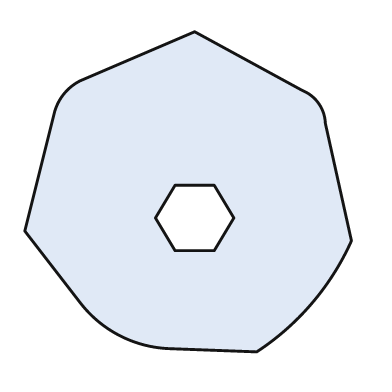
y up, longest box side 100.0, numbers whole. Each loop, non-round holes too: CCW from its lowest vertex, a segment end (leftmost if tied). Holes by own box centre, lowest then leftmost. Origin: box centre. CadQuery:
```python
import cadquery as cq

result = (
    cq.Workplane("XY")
    .moveTo(21.0, -49.0)
    .threePointArc((38.0, -34.0), (50.0, -15.0))
    .lineTo(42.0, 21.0)
    .threePointArc((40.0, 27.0), (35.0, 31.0))
    .lineTo(2.0, 49.0)
    .lineTo(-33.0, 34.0)
    .threePointArc((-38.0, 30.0), (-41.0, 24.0))
    .lineTo(-50.0, -12.0)
    .lineTo(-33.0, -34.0)
    .threePointArc((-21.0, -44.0), (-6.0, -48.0))
    .close()
    .moveTo(-4.0, -18.0)
    .lineTo(8.0, -18.0)
    .lineTo(14.0, -8.0)
    .lineTo(8.0, 2.0)
    .lineTo(-4.0, 2.0)
    .lineTo(-10.0, -8.0)
    .close()
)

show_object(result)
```